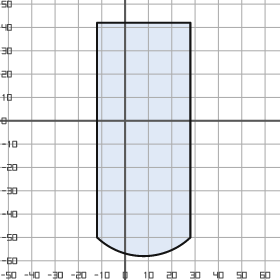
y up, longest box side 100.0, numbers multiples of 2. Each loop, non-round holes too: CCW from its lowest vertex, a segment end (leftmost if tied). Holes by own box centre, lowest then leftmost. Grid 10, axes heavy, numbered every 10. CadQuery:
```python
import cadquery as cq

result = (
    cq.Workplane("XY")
    .moveTo(-12.0, -50.0)
    .threePointArc((8.0, -58.0), (28.0, -50.0))
    .lineTo(28.0, 42.0)
    .lineTo(-12.0, 42.0)
    .close()
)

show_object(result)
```